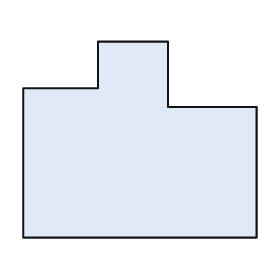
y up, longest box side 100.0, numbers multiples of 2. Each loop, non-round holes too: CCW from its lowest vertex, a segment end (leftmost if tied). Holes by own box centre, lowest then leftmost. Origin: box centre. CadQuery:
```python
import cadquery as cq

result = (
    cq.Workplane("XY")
    .moveTo(-50.0, -42.0)
    .lineTo(50.0, -42.0)
    .lineTo(50.0, 14.0)
    .lineTo(12.0, 14.0)
    .lineTo(12.0, 42.0)
    .lineTo(-18.0, 42.0)
    .lineTo(-18.0, 22.0)
    .lineTo(-50.0, 22.0)
    .close()
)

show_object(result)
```